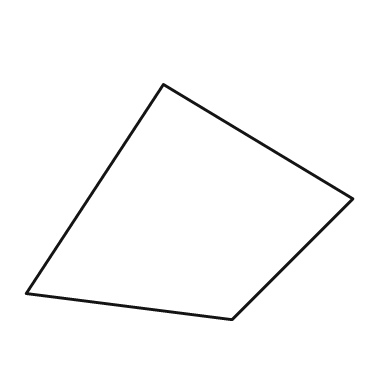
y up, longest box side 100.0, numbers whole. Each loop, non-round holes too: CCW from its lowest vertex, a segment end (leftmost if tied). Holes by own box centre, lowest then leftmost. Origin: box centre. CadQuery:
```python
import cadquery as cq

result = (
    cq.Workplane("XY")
    .moveTo(13.0, -36.0)
    .lineTo(50.0, 1.0)
    .lineTo(-8.0, 36.0)
    .lineTo(-50.0, -28.0)
    .close()
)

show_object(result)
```